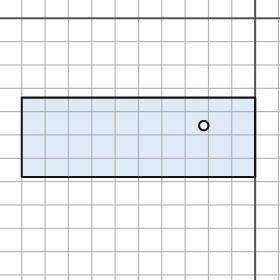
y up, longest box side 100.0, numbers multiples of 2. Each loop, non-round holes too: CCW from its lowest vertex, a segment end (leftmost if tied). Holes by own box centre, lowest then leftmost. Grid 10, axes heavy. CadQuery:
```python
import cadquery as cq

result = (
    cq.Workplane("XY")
    .moveTo(-100.0, -68.0)
    .lineTo(0.0, -68.0)
    .lineTo(0.0, -34.0)
    .lineTo(-100.0, -34.0)
    .close()
    .moveTo(-22.0, -46.0)
    .circle(2.0)
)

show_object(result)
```